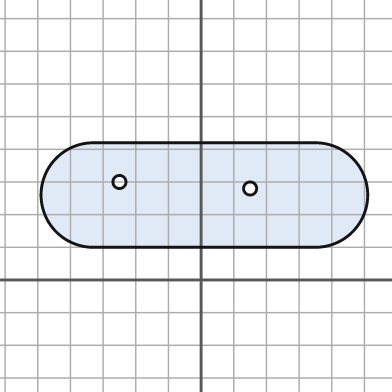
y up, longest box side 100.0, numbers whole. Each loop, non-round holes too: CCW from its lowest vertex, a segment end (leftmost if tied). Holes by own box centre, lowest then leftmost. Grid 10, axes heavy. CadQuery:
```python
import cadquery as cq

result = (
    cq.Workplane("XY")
    .moveTo(-33.0, 10.0)
    .lineTo(35.0, 10.0)
    .threePointArc((51.0, 26.0), (35.0, 42.0))
    .lineTo(-33.0, 42.0)
    .threePointArc((-49.0, 26.0), (-33.0, 10.0))
    .close()
    .moveTo(15.0, 28.0)
    .circle(2.0)
    .moveTo(-25.0, 30.0)
    .circle(2.0)
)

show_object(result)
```